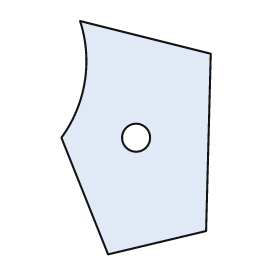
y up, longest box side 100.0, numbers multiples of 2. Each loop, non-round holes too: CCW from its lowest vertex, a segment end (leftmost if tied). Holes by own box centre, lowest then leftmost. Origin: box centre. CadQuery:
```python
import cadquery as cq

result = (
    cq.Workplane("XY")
    .moveTo(-12.0, -50.0)
    .lineTo(30.0, -40.0)
    .lineTo(32.0, 36.0)
    .lineTo(-24.0, 50.0)
    .threePointArc((-22.0, 24.0), (-32.0, 0.0))
    .close()
    .moveTo(0.0, 0.0)
    .circle(6.0)
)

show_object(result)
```